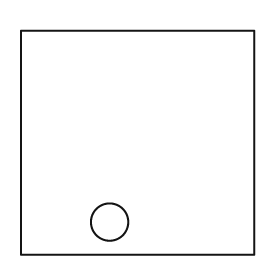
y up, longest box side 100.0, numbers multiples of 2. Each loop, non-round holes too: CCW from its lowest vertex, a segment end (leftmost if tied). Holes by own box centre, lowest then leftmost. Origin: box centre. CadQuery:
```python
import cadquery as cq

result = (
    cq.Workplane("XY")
    .moveTo(-50.0, -48.0)
    .lineTo(50.0, -48.0)
    .lineTo(50.0, 48.0)
    .lineTo(-50.0, 48.0)
    .close()
    .moveTo(-12.0, -34.0)
    .circle(8.0)
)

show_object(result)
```